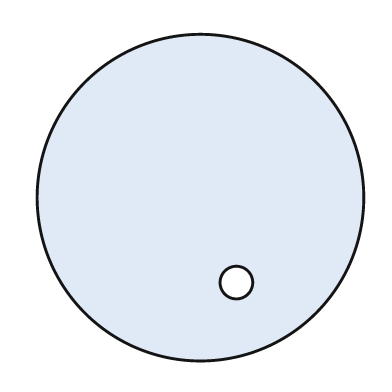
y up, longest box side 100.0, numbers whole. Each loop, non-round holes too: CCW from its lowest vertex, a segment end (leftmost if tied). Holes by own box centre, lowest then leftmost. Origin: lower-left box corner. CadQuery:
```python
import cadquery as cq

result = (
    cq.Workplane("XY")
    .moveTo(50.0, 50.0)
    .circle(50.0)
    .moveTo(61.0, 24.0)
    .circle(5.0)
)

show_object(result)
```